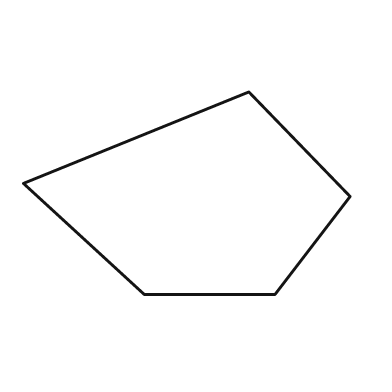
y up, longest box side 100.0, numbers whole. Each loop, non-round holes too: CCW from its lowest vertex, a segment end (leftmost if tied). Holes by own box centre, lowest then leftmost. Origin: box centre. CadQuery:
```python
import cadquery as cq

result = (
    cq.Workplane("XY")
    .moveTo(-13.0, -31.0)
    .lineTo(27.0, -31.0)
    .lineTo(50.0, -1.0)
    .lineTo(19.0, 31.0)
    .lineTo(-50.0, 3.0)
    .close()
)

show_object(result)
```